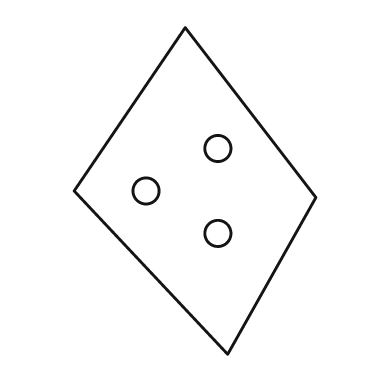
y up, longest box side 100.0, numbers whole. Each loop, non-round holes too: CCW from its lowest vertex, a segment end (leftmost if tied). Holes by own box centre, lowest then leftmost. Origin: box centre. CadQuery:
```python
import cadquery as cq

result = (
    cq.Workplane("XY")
    .moveTo(10.0, -50.0)
    .lineTo(37.0, -2.0)
    .lineTo(-3.0, 50.0)
    .lineTo(-37.0, 0.0)
    .close()
    .moveTo(7.0, -13.0)
    .circle(4.0)
    .moveTo(-15.0, 0.0)
    .circle(4.0)
    .moveTo(7.0, 13.0)
    .circle(4.0)
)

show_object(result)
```